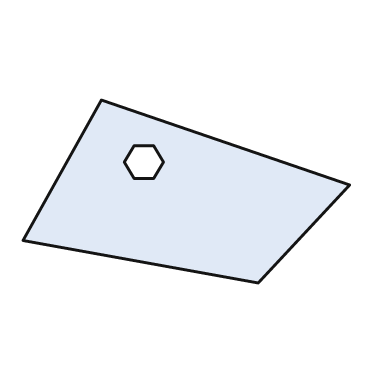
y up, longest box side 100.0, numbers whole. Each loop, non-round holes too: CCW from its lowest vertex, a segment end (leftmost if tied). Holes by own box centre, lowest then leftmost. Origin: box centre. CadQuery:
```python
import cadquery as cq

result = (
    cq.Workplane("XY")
    .moveTo(22.0, -28.0)
    .lineTo(50.0, 2.0)
    .lineTo(-26.0, 28.0)
    .lineTo(-50.0, -15.0)
    .close()
    .moveTo(-16.0, 4.0)
    .lineTo(-10.0, 4.0)
    .lineTo(-7.0, 9.0)
    .lineTo(-10.0, 14.0)
    .lineTo(-16.0, 14.0)
    .lineTo(-19.0, 9.0)
    .close()
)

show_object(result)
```